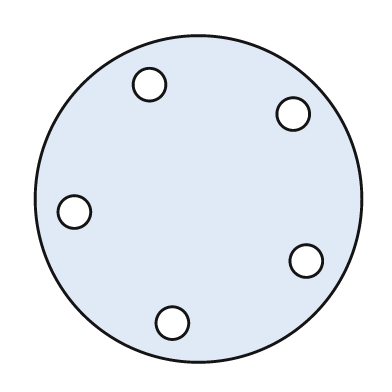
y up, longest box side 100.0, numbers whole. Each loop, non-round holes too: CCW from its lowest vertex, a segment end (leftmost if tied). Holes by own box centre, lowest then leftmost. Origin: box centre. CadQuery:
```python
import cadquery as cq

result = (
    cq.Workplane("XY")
    .moveTo(0.0, 0.0)
    .circle(50.0)
    .moveTo(-8.0, -38.0)
    .circle(5.0)
    .moveTo(33.0, -19.0)
    .circle(5.0)
    .moveTo(-38.0, -4.0)
    .circle(5.0)
    .moveTo(29.0, 26.0)
    .circle(5.0)
    .moveTo(-15.0, 35.0)
    .circle(5.0)
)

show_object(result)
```